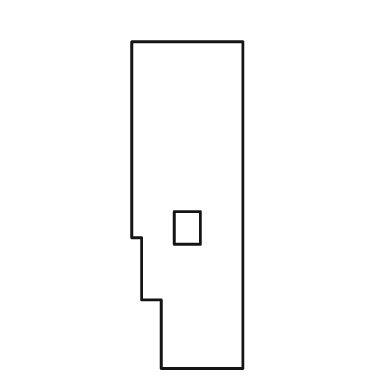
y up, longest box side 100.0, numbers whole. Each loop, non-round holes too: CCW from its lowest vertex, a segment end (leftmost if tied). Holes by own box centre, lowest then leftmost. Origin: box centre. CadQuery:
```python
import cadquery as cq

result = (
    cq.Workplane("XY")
    .moveTo(-8.0, -50.0)
    .lineTo(17.0, -50.0)
    .lineTo(17.0, 50.0)
    .lineTo(-17.0, 50.0)
    .lineTo(-17.0, -10.0)
    .lineTo(-14.0, -10.0)
    .lineTo(-14.0, -29.0)
    .lineTo(-8.0, -29.0)
    .close()
    .moveTo(-4.0, -12.0)
    .lineTo(4.0, -12.0)
    .lineTo(4.0, -2.0)
    .lineTo(-4.0, -2.0)
    .close()
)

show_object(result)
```